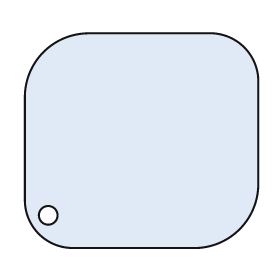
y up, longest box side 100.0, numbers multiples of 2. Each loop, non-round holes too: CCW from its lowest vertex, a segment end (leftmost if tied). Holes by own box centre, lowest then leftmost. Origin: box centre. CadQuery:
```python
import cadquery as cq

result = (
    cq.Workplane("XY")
    .moveTo(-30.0, -46.0)
    .lineTo(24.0, -46.0)
    .threePointArc((42.0, -38.0), (50.0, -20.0))
    .lineTo(50.0, 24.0)
    .threePointArc((44.0, 40.0), (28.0, 46.0))
    .lineTo(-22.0, 46.0)
    .threePointArc((-42.0, 38.0), (-50.0, 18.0))
    .lineTo(-50.0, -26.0)
    .threePointArc((-44.0, -40.0), (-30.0, -46.0))
    .close()
    .moveTo(-40.0, -32.0)
    .circle(4.0)
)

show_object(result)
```